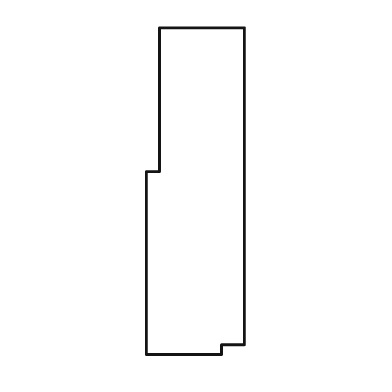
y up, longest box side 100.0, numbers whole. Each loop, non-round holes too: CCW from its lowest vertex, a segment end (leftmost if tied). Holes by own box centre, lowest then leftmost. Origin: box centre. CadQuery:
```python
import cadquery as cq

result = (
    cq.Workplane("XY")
    .moveTo(-15.0, -50.0)
    .lineTo(8.0, -50.0)
    .lineTo(8.0, -47.0)
    .lineTo(15.0, -47.0)
    .lineTo(15.0, 50.0)
    .lineTo(-11.0, 50.0)
    .lineTo(-11.0, 6.0)
    .lineTo(-15.0, 6.0)
    .close()
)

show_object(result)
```